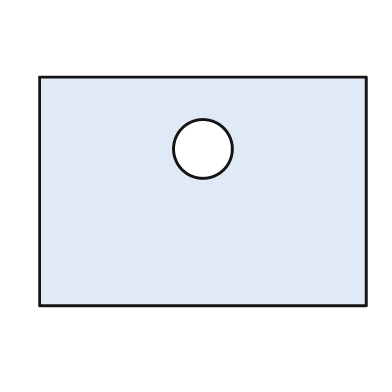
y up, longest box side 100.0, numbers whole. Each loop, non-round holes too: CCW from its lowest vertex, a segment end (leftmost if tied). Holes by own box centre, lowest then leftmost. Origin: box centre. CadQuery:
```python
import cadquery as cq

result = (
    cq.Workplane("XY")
    .moveTo(-50.0, -35.0)
    .lineTo(50.0, -35.0)
    .lineTo(50.0, 35.0)
    .lineTo(-50.0, 35.0)
    .close()
    .moveTo(0.0, 13.0)
    .circle(9.0)
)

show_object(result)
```